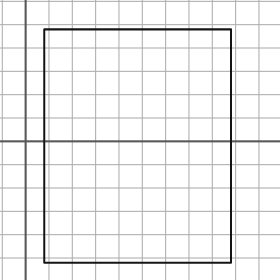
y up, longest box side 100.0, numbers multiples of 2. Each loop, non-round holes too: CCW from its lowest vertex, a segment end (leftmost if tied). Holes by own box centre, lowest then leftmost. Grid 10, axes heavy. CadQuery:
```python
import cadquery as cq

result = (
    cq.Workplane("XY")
    .moveTo(8.0, -52.0)
    .lineTo(88.0, -52.0)
    .lineTo(88.0, 48.0)
    .lineTo(8.0, 48.0)
    .close()
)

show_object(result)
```